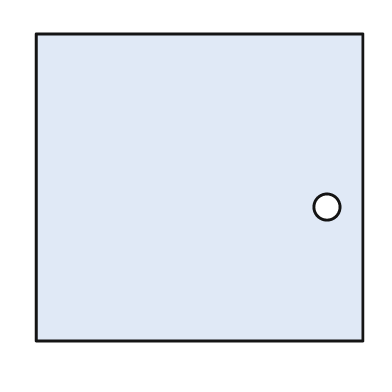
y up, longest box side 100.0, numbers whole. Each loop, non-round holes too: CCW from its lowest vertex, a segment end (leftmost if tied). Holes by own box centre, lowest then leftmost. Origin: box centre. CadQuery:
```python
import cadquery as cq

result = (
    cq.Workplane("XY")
    .moveTo(-50.0, -47.0)
    .lineTo(50.0, -47.0)
    .lineTo(50.0, 47.0)
    .lineTo(-50.0, 47.0)
    .close()
    .moveTo(39.0, -6.0)
    .circle(4.0)
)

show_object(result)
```